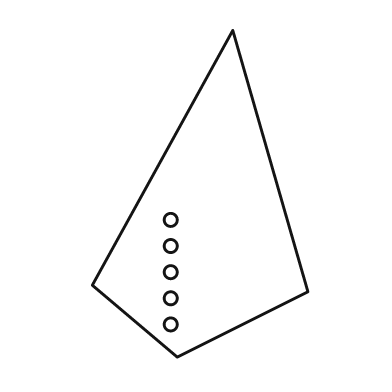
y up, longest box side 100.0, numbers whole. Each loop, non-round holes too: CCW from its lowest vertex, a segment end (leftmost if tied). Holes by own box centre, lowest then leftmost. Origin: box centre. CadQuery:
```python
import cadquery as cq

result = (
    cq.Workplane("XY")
    .moveTo(-7.0, -50.0)
    .lineTo(33.0, -30.0)
    .lineTo(10.0, 50.0)
    .lineTo(-33.0, -28.0)
    .close()
    .moveTo(-9.0, -40.0)
    .circle(2.0)
    .moveTo(-9.0, -32.0)
    .circle(2.0)
    .moveTo(-9.0, -24.0)
    .circle(2.0)
    .moveTo(-9.0, -16.0)
    .circle(2.0)
    .moveTo(-9.0, -8.0)
    .circle(2.0)
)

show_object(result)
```